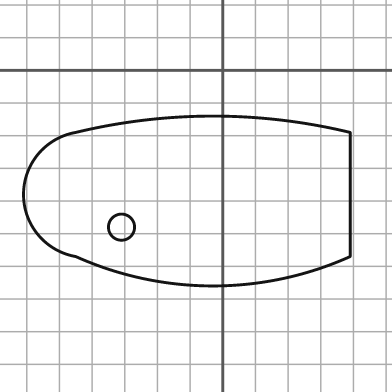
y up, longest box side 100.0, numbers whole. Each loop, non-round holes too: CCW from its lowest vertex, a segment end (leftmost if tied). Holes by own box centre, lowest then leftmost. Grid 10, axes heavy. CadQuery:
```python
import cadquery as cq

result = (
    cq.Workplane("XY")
    .moveTo(-45.0, -57.0)
    .threePointArc((-3.0, -66.0), (39.0, -57.0))
    .lineTo(39.0, -19.0)
    .threePointArc((-3.0, -14.0), (-45.0, -19.0))
    .threePointArc((-61.0, -38.0), (-45.0, -57.0))
    .close()
    .moveTo(-31.0, -48.0)
    .circle(4.0)
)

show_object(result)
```